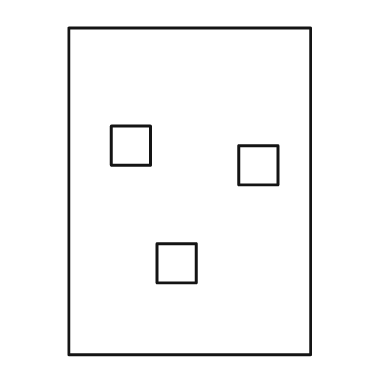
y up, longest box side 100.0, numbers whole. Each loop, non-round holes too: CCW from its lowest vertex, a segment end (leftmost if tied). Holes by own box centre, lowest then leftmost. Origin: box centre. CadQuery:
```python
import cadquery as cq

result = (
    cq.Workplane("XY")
    .moveTo(-37.0, -50.0)
    .lineTo(37.0, -50.0)
    .lineTo(37.0, 50.0)
    .lineTo(-37.0, 50.0)
    .close()
    .moveTo(-10.0, -28.0)
    .lineTo(2.0, -28.0)
    .lineTo(2.0, -16.0)
    .lineTo(-10.0, -16.0)
    .close()
    .moveTo(15.0, 2.0)
    .lineTo(27.0, 2.0)
    .lineTo(27.0, 14.0)
    .lineTo(15.0, 14.0)
    .close()
    .moveTo(-24.0, 8.0)
    .lineTo(-12.0, 8.0)
    .lineTo(-12.0, 20.0)
    .lineTo(-24.0, 20.0)
    .close()
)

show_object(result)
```